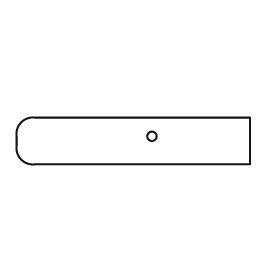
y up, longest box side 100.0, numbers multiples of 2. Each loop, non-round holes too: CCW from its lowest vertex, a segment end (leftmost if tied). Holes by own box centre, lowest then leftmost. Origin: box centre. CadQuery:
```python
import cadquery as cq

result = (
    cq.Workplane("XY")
    .moveTo(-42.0, -10.0)
    .lineTo(50.0, -10.0)
    .lineTo(50.0, 10.0)
    .lineTo(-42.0, 10.0)
    .threePointArc((-48.0, 8.0), (-50.0, 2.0))
    .lineTo(-50.0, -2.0)
    .threePointArc((-48.0, -8.0), (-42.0, -10.0))
    .close()
    .moveTo(8.0, 2.0)
    .circle(2.0)
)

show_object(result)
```